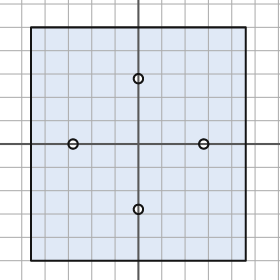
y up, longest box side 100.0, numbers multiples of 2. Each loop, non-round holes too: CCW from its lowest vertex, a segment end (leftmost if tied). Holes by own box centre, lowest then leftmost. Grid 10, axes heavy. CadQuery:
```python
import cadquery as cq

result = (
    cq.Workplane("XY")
    .moveTo(-46.0, -50.0)
    .lineTo(46.0, -50.0)
    .lineTo(46.0, 50.0)
    .lineTo(-46.0, 50.0)
    .close()
    .moveTo(0.0, -28.0)
    .circle(2.0)
    .moveTo(-28.0, 0.0)
    .circle(2.0)
    .moveTo(28.0, 0.0)
    .circle(2.0)
    .moveTo(0.0, 28.0)
    .circle(2.0)
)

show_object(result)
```